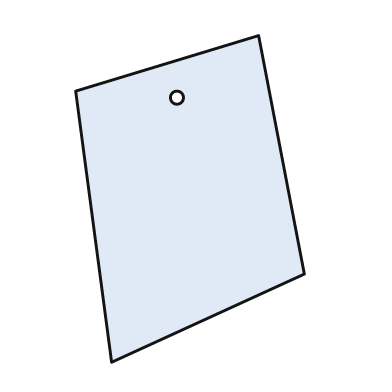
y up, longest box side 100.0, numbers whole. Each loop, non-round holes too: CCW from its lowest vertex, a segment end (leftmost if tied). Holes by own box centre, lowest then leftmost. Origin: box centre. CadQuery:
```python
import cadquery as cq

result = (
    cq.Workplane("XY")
    .moveTo(-24.0, -50.0)
    .lineTo(35.0, -23.0)
    .lineTo(21.0, 50.0)
    .lineTo(-35.0, 33.0)
    .close()
    .moveTo(-4.0, 31.0)
    .circle(2.0)
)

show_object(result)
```